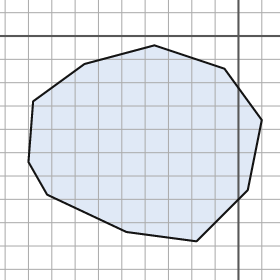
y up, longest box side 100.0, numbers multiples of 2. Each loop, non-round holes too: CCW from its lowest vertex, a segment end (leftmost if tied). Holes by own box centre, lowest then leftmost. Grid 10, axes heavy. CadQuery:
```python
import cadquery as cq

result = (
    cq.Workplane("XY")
    .moveTo(-18.0, -88.0)
    .lineTo(4.0, -66.0)
    .lineTo(10.0, -36.0)
    .lineTo(-6.0, -14.0)
    .lineTo(-36.0, -4.0)
    .lineTo(-66.0, -12.0)
    .lineTo(-88.0, -28.0)
    .lineTo(-90.0, -54.0)
    .lineTo(-82.0, -68.0)
    .lineTo(-48.0, -84.0)
    .close()
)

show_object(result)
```